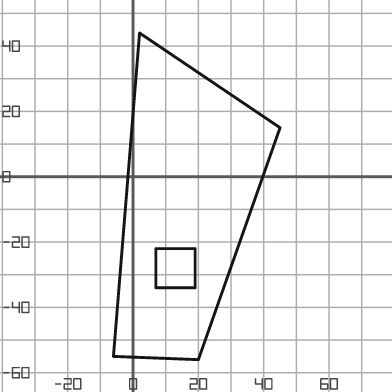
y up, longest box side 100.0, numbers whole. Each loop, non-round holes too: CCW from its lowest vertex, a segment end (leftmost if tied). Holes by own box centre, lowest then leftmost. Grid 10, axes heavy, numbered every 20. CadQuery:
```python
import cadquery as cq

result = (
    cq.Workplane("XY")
    .moveTo(20.0, -56.0)
    .lineTo(45.0, 15.0)
    .lineTo(2.0, 44.0)
    .lineTo(-6.0, -55.0)
    .close()
    .moveTo(7.0, -34.0)
    .lineTo(19.0, -34.0)
    .lineTo(19.0, -22.0)
    .lineTo(7.0, -22.0)
    .close()
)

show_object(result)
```